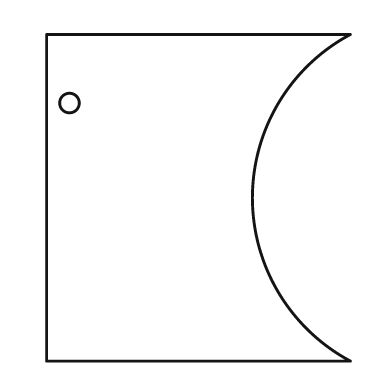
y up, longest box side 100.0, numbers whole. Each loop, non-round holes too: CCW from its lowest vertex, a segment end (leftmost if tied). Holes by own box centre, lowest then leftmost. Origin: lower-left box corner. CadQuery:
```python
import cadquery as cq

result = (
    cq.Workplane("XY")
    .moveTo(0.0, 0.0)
    .lineTo(93.0, 0.0)
    .threePointArc((63.0, 50.0), (93.0, 100.0))
    .lineTo(0.0, 100.0)
    .close()
    .moveTo(7.0, 79.0)
    .circle(3.0)
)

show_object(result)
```